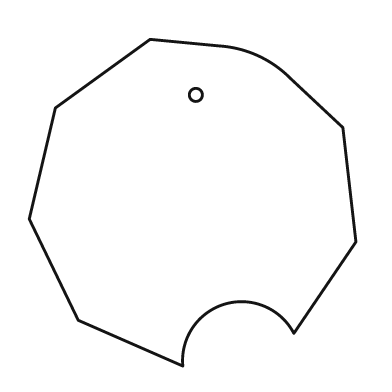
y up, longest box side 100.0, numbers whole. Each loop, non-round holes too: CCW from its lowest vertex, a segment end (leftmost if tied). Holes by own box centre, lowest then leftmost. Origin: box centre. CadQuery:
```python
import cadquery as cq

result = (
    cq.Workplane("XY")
    .moveTo(-3.0, -50.0)
    .threePointArc((10.0, -31.0), (31.0, -40.0))
    .lineTo(50.0, -12.0)
    .lineTo(46.0, 23.0)
    .lineTo(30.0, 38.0)
    .threePointArc((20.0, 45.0), (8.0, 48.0))
    .lineTo(-13.0, 50.0)
    .lineTo(-42.0, 29.0)
    .lineTo(-50.0, -5.0)
    .lineTo(-35.0, -36.0)
    .close()
    .moveTo(1.0, 33.0)
    .circle(2.0)
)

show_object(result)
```